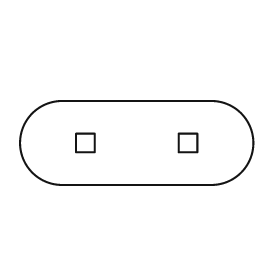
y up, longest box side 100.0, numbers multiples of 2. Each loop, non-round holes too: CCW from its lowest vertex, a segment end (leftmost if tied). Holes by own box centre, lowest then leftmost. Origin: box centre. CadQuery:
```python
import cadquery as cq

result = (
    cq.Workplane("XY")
    .moveTo(-32.0, -18.0)
    .lineTo(32.0, -18.0)
    .threePointArc((50.0, 0.0), (32.0, 18.0))
    .lineTo(-32.0, 18.0)
    .threePointArc((-50.0, 0.0), (-32.0, -18.0))
    .close()
    .moveTo(-26.0, -4.0)
    .lineTo(-18.0, -4.0)
    .lineTo(-18.0, 4.0)
    .lineTo(-26.0, 4.0)
    .close()
    .moveTo(18.0, -4.0)
    .lineTo(26.0, -4.0)
    .lineTo(26.0, 4.0)
    .lineTo(18.0, 4.0)
    .close()
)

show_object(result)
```